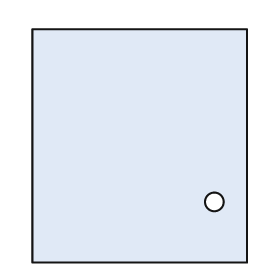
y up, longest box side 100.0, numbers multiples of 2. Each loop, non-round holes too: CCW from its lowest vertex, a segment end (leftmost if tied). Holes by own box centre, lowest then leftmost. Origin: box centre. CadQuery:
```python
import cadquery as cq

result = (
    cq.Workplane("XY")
    .moveTo(-46.0, -50.0)
    .lineTo(46.0, -50.0)
    .lineTo(46.0, 50.0)
    .lineTo(-46.0, 50.0)
    .close()
    .moveTo(32.0, -24.0)
    .circle(4.0)
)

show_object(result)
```